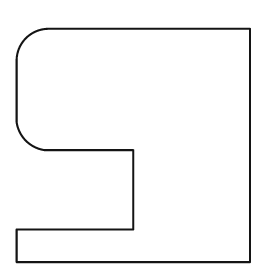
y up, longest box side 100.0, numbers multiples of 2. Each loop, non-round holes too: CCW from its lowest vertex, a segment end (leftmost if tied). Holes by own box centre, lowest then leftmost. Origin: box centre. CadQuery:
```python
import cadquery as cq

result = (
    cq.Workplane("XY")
    .moveTo(-50.0, -50.0)
    .lineTo(50.0, -50.0)
    .lineTo(50.0, 50.0)
    .lineTo(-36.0, 50.0)
    .threePointArc((-46.0, 46.0), (-50.0, 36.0))
    .lineTo(-50.0, 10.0)
    .threePointArc((-46.0, 2.0), (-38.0, -2.0))
    .lineTo(0.0, -2.0)
    .lineTo(0.0, -36.0)
    .lineTo(-50.0, -36.0)
    .close()
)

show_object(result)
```